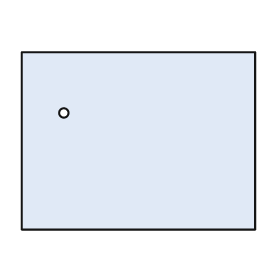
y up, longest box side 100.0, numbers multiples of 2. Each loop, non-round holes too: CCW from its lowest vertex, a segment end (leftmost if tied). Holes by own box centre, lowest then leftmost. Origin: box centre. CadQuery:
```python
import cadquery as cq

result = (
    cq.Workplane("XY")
    .moveTo(-50.0, -38.0)
    .lineTo(50.0, -38.0)
    .lineTo(50.0, 38.0)
    .lineTo(-50.0, 38.0)
    .close()
    .moveTo(-32.0, 12.0)
    .circle(2.0)
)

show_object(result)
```